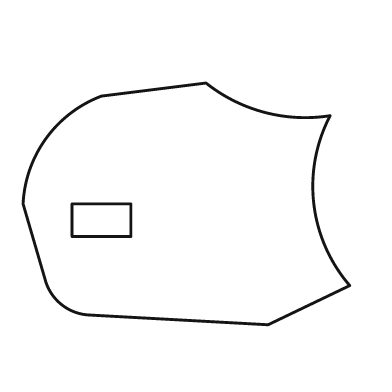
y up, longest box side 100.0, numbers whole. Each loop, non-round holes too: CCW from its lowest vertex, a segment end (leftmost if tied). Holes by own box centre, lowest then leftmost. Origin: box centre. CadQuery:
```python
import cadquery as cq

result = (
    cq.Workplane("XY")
    .moveTo(25.0, -37.0)
    .lineTo(50.0, -25.0)
    .threePointArc((39.0, 0.0), (44.0, 27.0))
    .threePointArc((24.0, 28.0), (6.0, 37.0))
    .lineTo(-26.0, 33.0)
    .threePointArc((-43.0, 20.0), (-50.0, 0.0))
    .lineTo(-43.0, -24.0)
    .threePointArc((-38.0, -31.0), (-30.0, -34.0))
    .close()
    .moveTo(-35.0, -10.0)
    .lineTo(-17.0, -10.0)
    .lineTo(-17.0, 0.0)
    .lineTo(-35.0, 0.0)
    .close()
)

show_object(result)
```